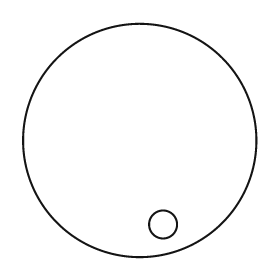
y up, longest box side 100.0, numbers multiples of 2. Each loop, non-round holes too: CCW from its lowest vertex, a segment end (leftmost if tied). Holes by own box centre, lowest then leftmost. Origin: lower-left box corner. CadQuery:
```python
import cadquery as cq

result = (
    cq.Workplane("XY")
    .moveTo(50.0, 50.0)
    .circle(50.0)
    .moveTo(60.0, 14.0)
    .circle(6.0)
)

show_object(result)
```